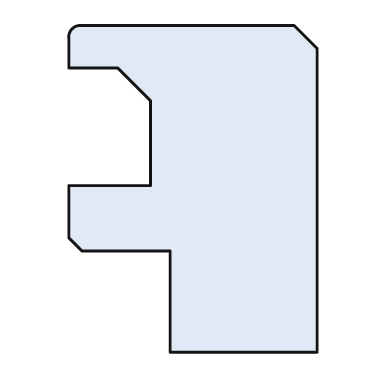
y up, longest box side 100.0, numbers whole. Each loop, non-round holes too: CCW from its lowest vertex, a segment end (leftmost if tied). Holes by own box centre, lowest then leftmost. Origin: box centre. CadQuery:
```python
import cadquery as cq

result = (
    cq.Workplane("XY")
    .moveTo(-7.0, -50.0)
    .lineTo(38.0, -50.0)
    .lineTo(38.0, 43.0)
    .lineTo(31.0, 50.0)
    .lineTo(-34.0, 50.0)
    .threePointArc((-37.0, 49.0), (-38.0, 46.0))
    .lineTo(-38.0, 37.0)
    .lineTo(-23.0, 37.0)
    .lineTo(-13.0, 27.0)
    .lineTo(-13.0, 1.0)
    .lineTo(-38.0, 1.0)
    .lineTo(-38.0, -15.0)
    .lineTo(-34.0, -19.0)
    .lineTo(-7.0, -19.0)
    .close()
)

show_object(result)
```